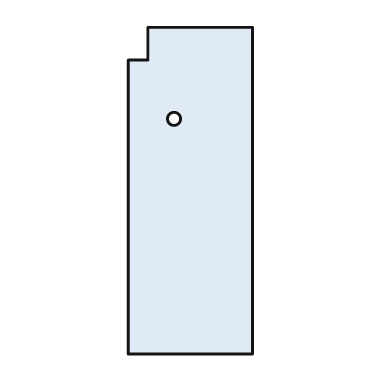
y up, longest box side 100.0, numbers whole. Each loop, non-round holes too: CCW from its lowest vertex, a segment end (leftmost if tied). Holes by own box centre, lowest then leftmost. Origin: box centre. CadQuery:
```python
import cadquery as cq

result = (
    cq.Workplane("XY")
    .moveTo(-19.0, -50.0)
    .lineTo(19.0, -50.0)
    .lineTo(19.0, 50.0)
    .lineTo(-13.0, 50.0)
    .lineTo(-13.0, 40.0)
    .lineTo(-19.0, 40.0)
    .close()
    .moveTo(-5.0, 22.0)
    .circle(2.0)
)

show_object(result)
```